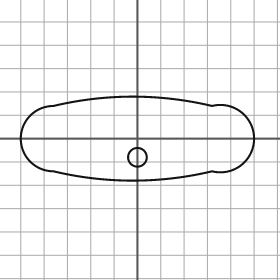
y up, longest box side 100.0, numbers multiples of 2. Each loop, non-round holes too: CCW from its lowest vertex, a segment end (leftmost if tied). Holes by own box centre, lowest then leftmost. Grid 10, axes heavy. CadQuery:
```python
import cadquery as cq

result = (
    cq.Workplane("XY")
    .moveTo(-36.0, -14.0)
    .threePointArc((-2.0, -18.0), (32.0, -14.0))
    .threePointArc((50.0, 0.0), (32.0, 14.0))
    .threePointArc((-2.0, 18.0), (-36.0, 14.0))
    .threePointArc((-50.0, 0.0), (-36.0, -14.0))
    .close()
    .moveTo(0.0, -8.0)
    .circle(4.0)
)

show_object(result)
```